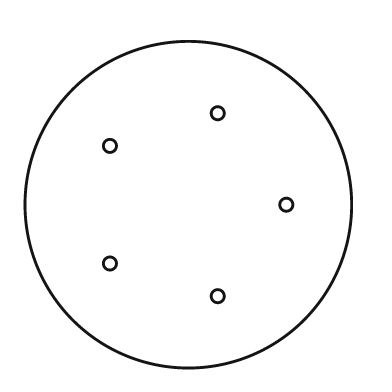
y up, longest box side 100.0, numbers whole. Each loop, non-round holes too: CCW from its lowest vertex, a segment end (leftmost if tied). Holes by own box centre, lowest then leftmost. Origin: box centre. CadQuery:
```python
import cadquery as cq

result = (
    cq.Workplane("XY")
    .moveTo(0.0, 0.0)
    .circle(50.0)
    .moveTo(9.0, -28.0)
    .circle(2.0)
    .moveTo(-24.0, -18.0)
    .circle(2.0)
    .moveTo(30.0, 0.0)
    .circle(2.0)
    .moveTo(-24.0, 18.0)
    .circle(2.0)
    .moveTo(9.0, 28.0)
    .circle(2.0)
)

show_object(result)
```